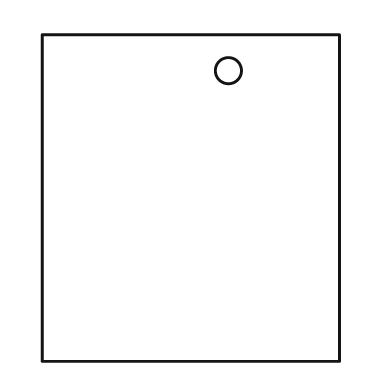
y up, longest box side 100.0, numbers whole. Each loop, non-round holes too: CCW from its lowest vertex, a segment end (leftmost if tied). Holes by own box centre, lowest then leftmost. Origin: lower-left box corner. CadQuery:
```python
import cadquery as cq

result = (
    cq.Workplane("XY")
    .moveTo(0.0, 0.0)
    .lineTo(91.0, 0.0)
    .lineTo(91.0, 100.0)
    .lineTo(0.0, 100.0)
    .close()
    .moveTo(57.0, 89.0)
    .circle(4.0)
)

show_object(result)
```